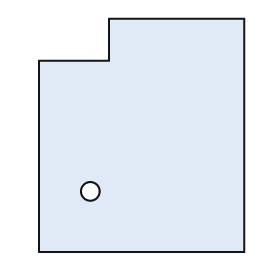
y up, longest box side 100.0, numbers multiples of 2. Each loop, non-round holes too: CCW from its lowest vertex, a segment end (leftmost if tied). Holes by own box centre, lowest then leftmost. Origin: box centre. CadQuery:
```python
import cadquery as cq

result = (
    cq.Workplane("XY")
    .moveTo(-44.0, -50.0)
    .lineTo(44.0, -50.0)
    .lineTo(44.0, 50.0)
    .lineTo(-14.0, 50.0)
    .lineTo(-14.0, 32.0)
    .lineTo(-44.0, 32.0)
    .close()
    .moveTo(-22.0, -24.0)
    .circle(4.0)
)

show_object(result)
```